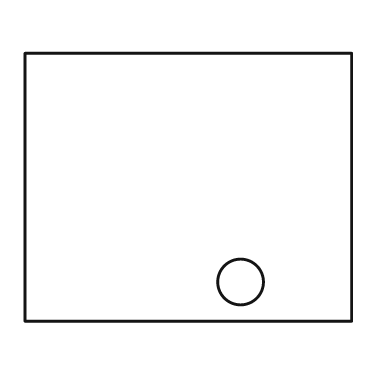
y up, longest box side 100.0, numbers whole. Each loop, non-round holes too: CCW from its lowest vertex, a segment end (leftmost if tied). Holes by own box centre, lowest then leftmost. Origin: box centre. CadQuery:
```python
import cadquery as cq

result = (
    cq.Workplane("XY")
    .moveTo(-50.0, -41.0)
    .lineTo(50.0, -41.0)
    .lineTo(50.0, 41.0)
    .lineTo(-50.0, 41.0)
    .close()
    .moveTo(16.0, -29.0)
    .circle(7.0)
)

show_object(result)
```